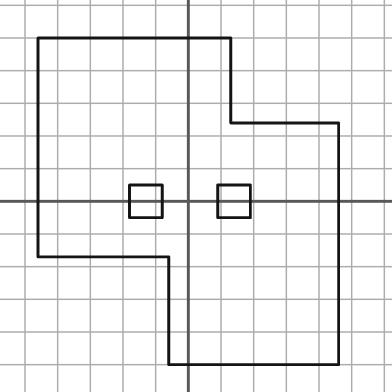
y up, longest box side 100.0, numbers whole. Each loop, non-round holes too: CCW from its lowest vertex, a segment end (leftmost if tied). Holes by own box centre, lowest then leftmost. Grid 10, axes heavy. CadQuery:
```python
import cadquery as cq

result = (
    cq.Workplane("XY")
    .moveTo(-6.0, -50.0)
    .lineTo(46.0, -50.0)
    .lineTo(46.0, 24.0)
    .lineTo(13.0, 24.0)
    .lineTo(13.0, 50.0)
    .lineTo(-46.0, 50.0)
    .lineTo(-46.0, -17.0)
    .lineTo(-6.0, -17.0)
    .close()
    .moveTo(-18.0, -5.0)
    .lineTo(-8.0, -5.0)
    .lineTo(-8.0, 5.0)
    .lineTo(-18.0, 5.0)
    .close()
    .moveTo(9.0, -5.0)
    .lineTo(19.0, -5.0)
    .lineTo(19.0, 5.0)
    .lineTo(9.0, 5.0)
    .close()
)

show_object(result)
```